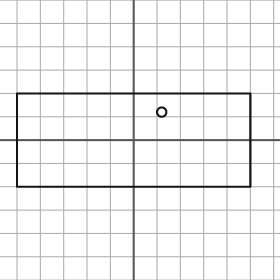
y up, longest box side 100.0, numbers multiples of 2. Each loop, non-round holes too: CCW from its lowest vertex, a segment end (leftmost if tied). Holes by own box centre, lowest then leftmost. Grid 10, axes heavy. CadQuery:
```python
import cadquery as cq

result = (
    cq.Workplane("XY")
    .moveTo(-50.0, -20.0)
    .lineTo(50.0, -20.0)
    .lineTo(50.0, 20.0)
    .lineTo(-50.0, 20.0)
    .close()
    .moveTo(12.0, 12.0)
    .circle(2.0)
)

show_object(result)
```